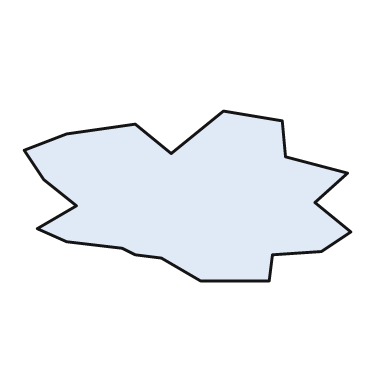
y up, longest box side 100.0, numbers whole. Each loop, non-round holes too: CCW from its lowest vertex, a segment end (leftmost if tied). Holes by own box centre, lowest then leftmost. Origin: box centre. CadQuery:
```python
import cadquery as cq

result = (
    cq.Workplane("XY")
    .moveTo(4.0, -26.0)
    .lineTo(25.0, -26.0)
    .lineTo(26.0, -18.0)
    .lineTo(41.0, -17.0)
    .lineTo(50.0, -11.0)
    .lineTo(39.0, -2.0)
    .lineTo(49.0, 7.0)
    .lineTo(30.0, 12.0)
    .lineTo(29.0, 23.0)
    .lineTo(11.0, 26.0)
    .lineTo(-5.0, 13.0)
    .lineTo(-16.0, 22.0)
    .lineTo(-37.0, 19.0)
    .lineTo(-50.0, 14.0)
    .lineTo(-44.0, 5.0)
    .lineTo(-34.0, -3.0)
    .lineTo(-46.0, -10.0)
    .lineTo(-37.0, -14.0)
    .lineTo(-20.0, -16.0)
    .lineTo(-16.0, -18.0)
    .lineTo(-8.0, -19.0)
    .close()
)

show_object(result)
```